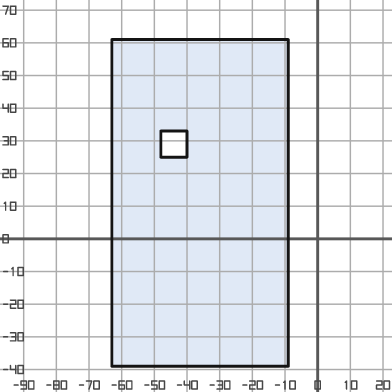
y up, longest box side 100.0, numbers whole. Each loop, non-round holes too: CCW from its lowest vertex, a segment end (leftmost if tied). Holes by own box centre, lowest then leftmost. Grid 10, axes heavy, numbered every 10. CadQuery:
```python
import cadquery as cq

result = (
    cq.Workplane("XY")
    .moveTo(-63.0, -39.0)
    .lineTo(-9.0, -39.0)
    .lineTo(-9.0, 61.0)
    .lineTo(-63.0, 61.0)
    .close()
    .moveTo(-48.0, 25.0)
    .lineTo(-40.0, 25.0)
    .lineTo(-40.0, 33.0)
    .lineTo(-48.0, 33.0)
    .close()
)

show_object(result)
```